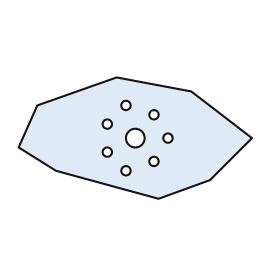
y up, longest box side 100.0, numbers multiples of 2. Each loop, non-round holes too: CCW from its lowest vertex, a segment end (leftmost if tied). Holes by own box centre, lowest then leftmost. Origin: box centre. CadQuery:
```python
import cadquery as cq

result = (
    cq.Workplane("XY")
    .moveTo(10.0, -26.0)
    .lineTo(32.0, -18.0)
    .lineTo(50.0, 0.0)
    .lineTo(24.0, 20.0)
    .lineTo(-8.0, 26.0)
    .lineTo(-42.0, 14.0)
    .lineTo(-50.0, -4.0)
    .lineTo(-34.0, -14.0)
    .close()
    .moveTo(-4.0, -14.0)
    .circle(2.0)
    .moveTo(8.0, -10.0)
    .circle(2.0)
    .moveTo(-12.0, -6.0)
    .circle(2.0)
    .moveTo(0.0, 0.0)
    .circle(4.0)
    .moveTo(14.0, 0.0)
    .circle(2.0)
    .moveTo(-12.0, 6.0)
    .circle(2.0)
    .moveTo(8.0, 10.0)
    .circle(2.0)
    .moveTo(-4.0, 14.0)
    .circle(2.0)
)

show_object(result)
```